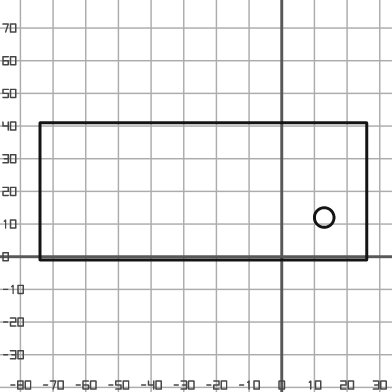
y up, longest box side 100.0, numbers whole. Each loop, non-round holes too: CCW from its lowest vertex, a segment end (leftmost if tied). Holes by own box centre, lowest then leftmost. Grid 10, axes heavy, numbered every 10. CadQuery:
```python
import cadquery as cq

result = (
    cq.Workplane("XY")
    .moveTo(-74.0, -1.0)
    .lineTo(26.0, -1.0)
    .lineTo(26.0, 41.0)
    .lineTo(-74.0, 41.0)
    .close()
    .moveTo(13.0, 12.0)
    .circle(3.0)
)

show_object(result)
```